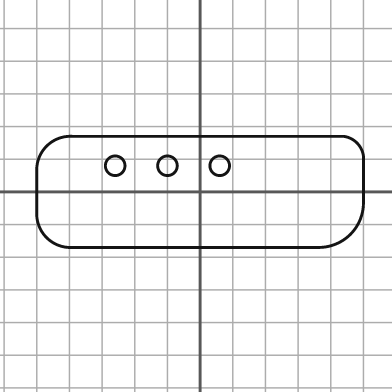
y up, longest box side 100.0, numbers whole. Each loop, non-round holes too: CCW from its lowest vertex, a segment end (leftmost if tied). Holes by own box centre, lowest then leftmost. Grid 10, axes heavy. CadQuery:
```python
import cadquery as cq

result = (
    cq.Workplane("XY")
    .moveTo(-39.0, -17.0)
    .lineTo(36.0, -17.0)
    .threePointArc((46.0, -13.0), (50.0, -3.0))
    .lineTo(50.0, 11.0)
    .threePointArc((48.0, 15.0), (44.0, 17.0))
    .lineTo(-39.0, 17.0)
    .threePointArc((-47.0, 14.0), (-50.0, 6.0))
    .lineTo(-50.0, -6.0)
    .threePointArc((-47.0, -14.0), (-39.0, -17.0))
    .close()
    .moveTo(-26.0, 8.0)
    .circle(3.0)
    .moveTo(-10.0, 8.0)
    .circle(3.0)
    .moveTo(6.0, 8.0)
    .circle(3.0)
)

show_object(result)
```